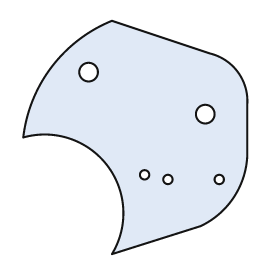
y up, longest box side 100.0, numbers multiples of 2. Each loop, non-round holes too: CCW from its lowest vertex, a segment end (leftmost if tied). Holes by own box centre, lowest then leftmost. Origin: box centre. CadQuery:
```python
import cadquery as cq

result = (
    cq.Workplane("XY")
    .moveTo(-10.0, -50.0)
    .lineTo(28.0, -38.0)
    .threePointArc((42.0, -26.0), (48.0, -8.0))
    .lineTo(48.0, 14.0)
    .threePointArc((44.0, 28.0), (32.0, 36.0))
    .lineTo(-10.0, 50.0)
    .threePointArc((-36.0, 30.0), (-48.0, 0.0))
    .threePointArc((-12.0, -12.0), (-10.0, -50.0))
    .close()
    .moveTo(14.0, -18.0)
    .circle(2.0)
    .moveTo(36.0, -18.0)
    .circle(2.0)
    .moveTo(4.0, -16.0)
    .circle(2.0)
    .moveTo(30.0, 10.0)
    .circle(4.0)
    .moveTo(-20.0, 28.0)
    .circle(4.0)
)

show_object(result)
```